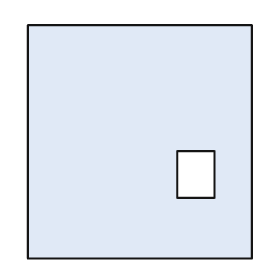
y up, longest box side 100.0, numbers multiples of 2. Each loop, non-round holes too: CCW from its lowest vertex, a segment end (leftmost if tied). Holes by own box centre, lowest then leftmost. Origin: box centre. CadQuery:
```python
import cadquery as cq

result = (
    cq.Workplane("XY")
    .moveTo(-48.0, -50.0)
    .lineTo(48.0, -50.0)
    .lineTo(48.0, 50.0)
    .lineTo(-48.0, 50.0)
    .close()
    .moveTo(16.0, -24.0)
    .lineTo(32.0, -24.0)
    .lineTo(32.0, -4.0)
    .lineTo(16.0, -4.0)
    .close()
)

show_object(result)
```